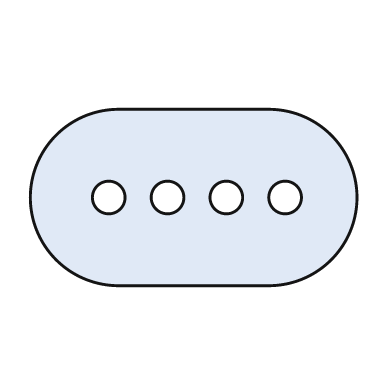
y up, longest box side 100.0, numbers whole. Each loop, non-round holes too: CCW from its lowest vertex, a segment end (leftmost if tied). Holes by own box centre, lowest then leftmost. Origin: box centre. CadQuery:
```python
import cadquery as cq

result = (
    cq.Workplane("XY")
    .moveTo(-23.0, -27.0)
    .lineTo(23.0, -27.0)
    .threePointArc((50.0, 0.0), (23.0, 27.0))
    .lineTo(-23.0, 27.0)
    .threePointArc((-50.0, 0.0), (-23.0, -27.0))
    .close()
    .moveTo(-26.0, 0.0)
    .circle(5.0)
    .moveTo(-8.0, 0.0)
    .circle(5.0)
    .moveTo(10.0, 0.0)
    .circle(5.0)
    .moveTo(28.0, 0.0)
    .circle(5.0)
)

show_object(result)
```